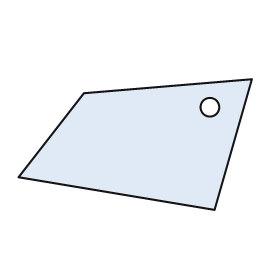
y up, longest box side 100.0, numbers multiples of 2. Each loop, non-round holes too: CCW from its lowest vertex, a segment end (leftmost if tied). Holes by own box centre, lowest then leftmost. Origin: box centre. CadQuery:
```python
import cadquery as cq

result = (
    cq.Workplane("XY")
    .moveTo(34.0, -28.0)
    .lineTo(50.0, 28.0)
    .lineTo(-22.0, 22.0)
    .lineTo(-50.0, -14.0)
    .close()
    .moveTo(32.0, 16.0)
    .circle(4.0)
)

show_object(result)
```